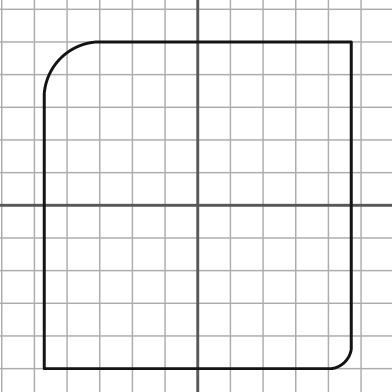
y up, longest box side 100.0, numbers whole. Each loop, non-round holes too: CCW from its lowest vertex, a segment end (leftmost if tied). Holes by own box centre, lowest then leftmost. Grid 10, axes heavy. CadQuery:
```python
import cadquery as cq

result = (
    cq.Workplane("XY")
    .moveTo(-47.0, -50.0)
    .lineTo(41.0, -50.0)
    .threePointArc((45.0, -48.0), (47.0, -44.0))
    .lineTo(47.0, 50.0)
    .lineTo(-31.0, 50.0)
    .threePointArc((-42.0, 45.0), (-47.0, 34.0))
    .close()
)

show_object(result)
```